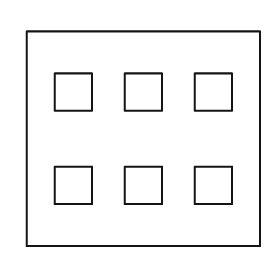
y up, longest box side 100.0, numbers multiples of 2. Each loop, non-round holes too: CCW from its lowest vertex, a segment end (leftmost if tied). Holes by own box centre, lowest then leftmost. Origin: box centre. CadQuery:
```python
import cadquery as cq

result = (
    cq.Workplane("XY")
    .moveTo(-50.0, -46.0)
    .lineTo(50.0, -46.0)
    .lineTo(50.0, 46.0)
    .lineTo(-50.0, 46.0)
    .close()
    .moveTo(-38.0, -28.0)
    .lineTo(-22.0, -28.0)
    .lineTo(-22.0, -12.0)
    .lineTo(-38.0, -12.0)
    .close()
    .moveTo(-8.0, -28.0)
    .lineTo(8.0, -28.0)
    .lineTo(8.0, -12.0)
    .lineTo(-8.0, -12.0)
    .close()
    .moveTo(22.0, -28.0)
    .lineTo(38.0, -28.0)
    .lineTo(38.0, -12.0)
    .lineTo(22.0, -12.0)
    .close()
    .moveTo(-38.0, 12.0)
    .lineTo(-22.0, 12.0)
    .lineTo(-22.0, 28.0)
    .lineTo(-38.0, 28.0)
    .close()
    .moveTo(-8.0, 12.0)
    .lineTo(8.0, 12.0)
    .lineTo(8.0, 28.0)
    .lineTo(-8.0, 28.0)
    .close()
    .moveTo(22.0, 12.0)
    .lineTo(38.0, 12.0)
    .lineTo(38.0, 28.0)
    .lineTo(22.0, 28.0)
    .close()
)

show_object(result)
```